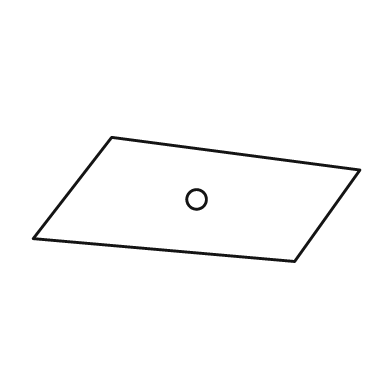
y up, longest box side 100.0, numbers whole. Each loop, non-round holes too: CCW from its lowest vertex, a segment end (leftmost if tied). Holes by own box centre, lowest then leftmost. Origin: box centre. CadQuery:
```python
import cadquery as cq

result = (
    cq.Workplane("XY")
    .moveTo(30.0, -19.0)
    .lineTo(50.0, 9.0)
    .lineTo(-26.0, 19.0)
    .lineTo(-50.0, -12.0)
    .close()
    .moveTo(0.0, 0.0)
    .circle(3.0)
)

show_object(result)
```